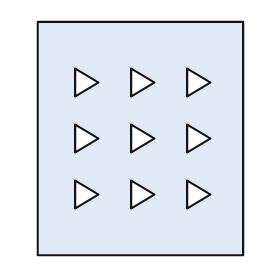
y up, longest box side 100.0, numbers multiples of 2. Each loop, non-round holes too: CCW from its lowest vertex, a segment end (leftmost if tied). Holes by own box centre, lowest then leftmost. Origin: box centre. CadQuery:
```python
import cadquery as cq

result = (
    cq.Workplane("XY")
    .moveTo(-44.0, -50.0)
    .lineTo(44.0, -50.0)
    .lineTo(44.0, 50.0)
    .lineTo(-44.0, 50.0)
    .close()
    .moveTo(-28.0, -30.0)
    .lineTo(-18.0, -24.0)
    .lineTo(-28.0, -18.0)
    .close()
    .moveTo(-4.0, -30.0)
    .lineTo(6.0, -24.0)
    .lineTo(-4.0, -18.0)
    .close()
    .moveTo(20.0, -30.0)
    .lineTo(30.0, -24.0)
    .lineTo(20.0, -18.0)
    .close()
    .moveTo(-28.0, -6.0)
    .lineTo(-18.0, 0.0)
    .lineTo(-28.0, 6.0)
    .close()
    .moveTo(-4.0, -6.0)
    .lineTo(6.0, 0.0)
    .lineTo(-4.0, 6.0)
    .close()
    .moveTo(20.0, -6.0)
    .lineTo(30.0, 0.0)
    .lineTo(20.0, 6.0)
    .close()
    .moveTo(-28.0, 18.0)
    .lineTo(-18.0, 24.0)
    .lineTo(-28.0, 30.0)
    .close()
    .moveTo(-4.0, 18.0)
    .lineTo(6.0, 24.0)
    .lineTo(-4.0, 30.0)
    .close()
    .moveTo(20.0, 18.0)
    .lineTo(30.0, 24.0)
    .lineTo(20.0, 30.0)
    .close()
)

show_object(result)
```